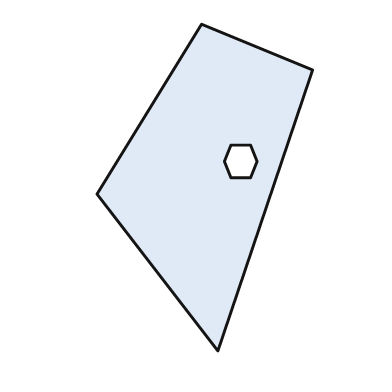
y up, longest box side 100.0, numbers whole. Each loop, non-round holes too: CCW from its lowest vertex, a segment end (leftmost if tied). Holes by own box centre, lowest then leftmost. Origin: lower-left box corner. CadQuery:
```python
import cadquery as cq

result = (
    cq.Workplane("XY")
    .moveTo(37.0, 0.0)
    .lineTo(66.0, 86.0)
    .lineTo(32.0, 100.0)
    .lineTo(0.0, 48.0)
    .close()
    .moveTo(41.0, 53.0)
    .lineTo(47.0, 53.0)
    .lineTo(49.0, 58.0)
    .lineTo(47.0, 63.0)
    .lineTo(41.0, 63.0)
    .lineTo(39.0, 58.0)
    .close()
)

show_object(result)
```